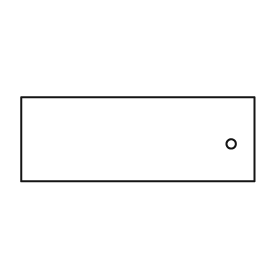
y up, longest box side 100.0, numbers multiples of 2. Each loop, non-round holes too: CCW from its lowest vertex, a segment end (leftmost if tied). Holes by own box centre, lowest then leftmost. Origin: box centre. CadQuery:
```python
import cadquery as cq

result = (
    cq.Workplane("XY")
    .moveTo(-50.0, -18.0)
    .lineTo(50.0, -18.0)
    .lineTo(50.0, 18.0)
    .lineTo(-50.0, 18.0)
    .close()
    .moveTo(40.0, -2.0)
    .circle(2.0)
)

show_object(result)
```